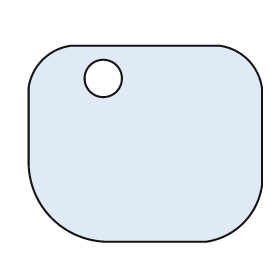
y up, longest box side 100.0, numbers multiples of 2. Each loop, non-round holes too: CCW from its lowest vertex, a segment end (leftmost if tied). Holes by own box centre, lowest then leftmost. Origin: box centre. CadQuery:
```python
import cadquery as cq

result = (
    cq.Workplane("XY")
    .moveTo(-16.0, -42.0)
    .lineTo(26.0, -42.0)
    .threePointArc((42.0, -34.0), (50.0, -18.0))
    .lineTo(50.0, 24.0)
    .threePointArc((44.0, 36.0), (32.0, 42.0))
    .lineTo(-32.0, 42.0)
    .threePointArc((-44.0, 36.0), (-50.0, 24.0))
    .lineTo(-50.0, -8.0)
    .threePointArc((-40.0, -32.0), (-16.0, -42.0))
    .close()
    .moveTo(-18.0, 28.0)
    .circle(8.0)
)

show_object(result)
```